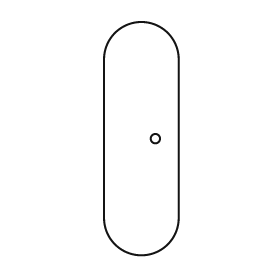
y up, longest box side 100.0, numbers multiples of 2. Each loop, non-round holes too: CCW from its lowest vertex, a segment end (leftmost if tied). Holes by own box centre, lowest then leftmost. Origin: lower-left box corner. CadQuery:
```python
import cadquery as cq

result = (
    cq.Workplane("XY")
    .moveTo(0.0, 16.0)
    .threePointArc((16.0, 0.0), (32.0, 16.0))
    .lineTo(32.0, 84.0)
    .threePointArc((16.0, 100.0), (0.0, 84.0))
    .close()
    .moveTo(22.0, 50.0)
    .circle(2.0)
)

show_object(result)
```